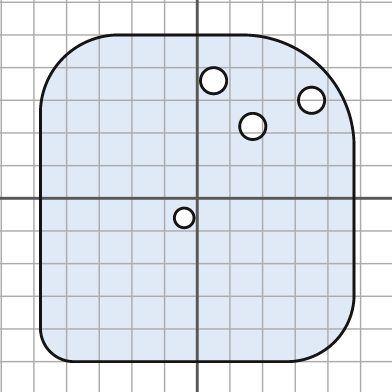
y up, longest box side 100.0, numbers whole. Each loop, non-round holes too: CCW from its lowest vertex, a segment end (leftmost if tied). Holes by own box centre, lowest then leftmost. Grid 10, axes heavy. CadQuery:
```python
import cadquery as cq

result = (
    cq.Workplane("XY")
    .moveTo(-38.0, -50.0)
    .lineTo(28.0, -50.0)
    .threePointArc((42.0, -44.0), (48.0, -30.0))
    .lineTo(48.0, 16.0)
    .threePointArc((38.0, 40.0), (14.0, 50.0))
    .lineTo(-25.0, 50.0)
    .threePointArc((-41.0, 43.0), (-48.0, 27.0))
    .lineTo(-48.0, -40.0)
    .threePointArc((-45.0, -47.0), (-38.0, -50.0))
    .close()
    .moveTo(-4.0, -6.0)
    .circle(3.0)
    .moveTo(17.0, 22.0)
    .circle(4.0)
    .moveTo(35.0, 30.0)
    .circle(4.0)
    .moveTo(5.0, 36.0)
    .circle(4.0)
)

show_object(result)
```